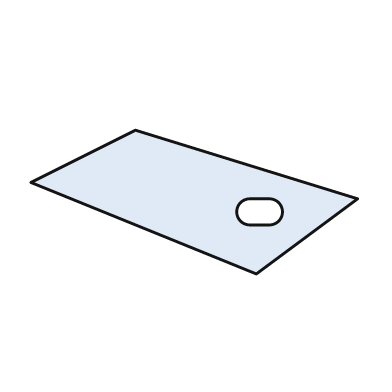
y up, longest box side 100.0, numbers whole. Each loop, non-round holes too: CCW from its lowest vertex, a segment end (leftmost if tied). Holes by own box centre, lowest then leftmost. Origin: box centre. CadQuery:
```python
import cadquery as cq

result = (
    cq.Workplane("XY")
    .moveTo(19.0, -22.0)
    .lineTo(50.0, 1.0)
    .lineTo(-18.0, 22.0)
    .lineTo(-50.0, 6.0)
    .close()
    .moveTo(17.0, -7.0)
    .lineTo(23.0, -7.0)
    .threePointArc((27.0, -3.0), (23.0, 1.0))
    .lineTo(17.0, 1.0)
    .threePointArc((13.0, -3.0), (17.0, -7.0))
    .close()
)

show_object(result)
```